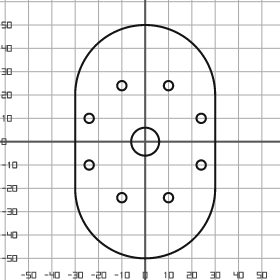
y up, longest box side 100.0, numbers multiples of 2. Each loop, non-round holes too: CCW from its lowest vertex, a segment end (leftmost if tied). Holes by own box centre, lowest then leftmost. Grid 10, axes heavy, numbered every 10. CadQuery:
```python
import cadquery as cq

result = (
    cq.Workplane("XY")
    .moveTo(-30.0, -20.0)
    .threePointArc((0.0, -50.0), (30.0, -20.0))
    .lineTo(30.0, 20.0)
    .threePointArc((0.0, 50.0), (-30.0, 20.0))
    .close()
    .moveTo(-10.0, -24.0)
    .circle(2.0)
    .moveTo(10.0, -24.0)
    .circle(2.0)
    .moveTo(-24.0, -10.0)
    .circle(2.0)
    .moveTo(24.0, -10.0)
    .circle(2.0)
    .moveTo(0.0, 0.0)
    .circle(6.0)
    .moveTo(-24.0, 10.0)
    .circle(2.0)
    .moveTo(24.0, 10.0)
    .circle(2.0)
    .moveTo(-10.0, 24.0)
    .circle(2.0)
    .moveTo(10.0, 24.0)
    .circle(2.0)
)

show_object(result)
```